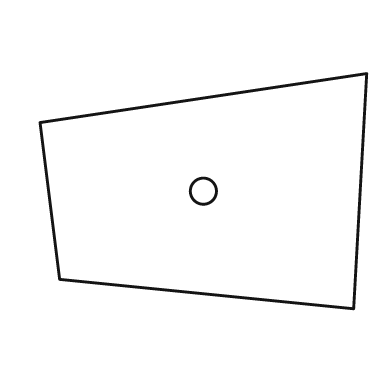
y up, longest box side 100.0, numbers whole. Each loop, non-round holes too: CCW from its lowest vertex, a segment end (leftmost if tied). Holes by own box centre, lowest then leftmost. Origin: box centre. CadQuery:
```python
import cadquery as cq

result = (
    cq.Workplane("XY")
    .moveTo(46.0, -36.0)
    .lineTo(50.0, 36.0)
    .lineTo(-50.0, 21.0)
    .lineTo(-44.0, -27.0)
    .close()
    .moveTo(0.0, 0.0)
    .circle(4.0)
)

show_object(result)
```